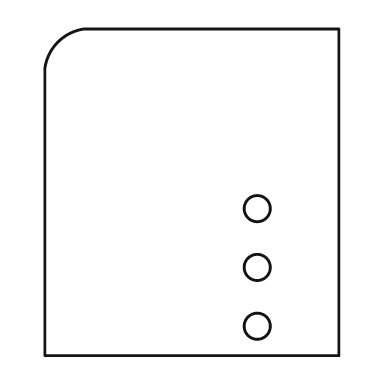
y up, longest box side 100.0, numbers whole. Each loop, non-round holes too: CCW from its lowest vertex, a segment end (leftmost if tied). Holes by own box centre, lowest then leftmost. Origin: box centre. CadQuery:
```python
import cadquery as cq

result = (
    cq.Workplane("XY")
    .moveTo(-45.0, -50.0)
    .lineTo(45.0, -50.0)
    .lineTo(45.0, 50.0)
    .lineTo(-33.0, 50.0)
    .threePointArc((-41.0, 46.0), (-45.0, 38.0))
    .close()
    .moveTo(20.0, -41.0)
    .circle(4.0)
    .moveTo(20.0, -23.0)
    .circle(4.0)
    .moveTo(20.0, -5.0)
    .circle(4.0)
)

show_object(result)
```